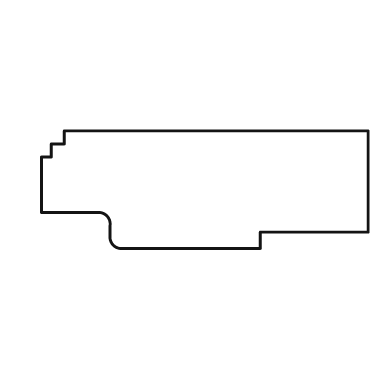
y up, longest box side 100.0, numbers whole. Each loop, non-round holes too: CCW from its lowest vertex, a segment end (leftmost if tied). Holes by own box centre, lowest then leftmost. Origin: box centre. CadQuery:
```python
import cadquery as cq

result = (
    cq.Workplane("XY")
    .moveTo(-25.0, -18.0)
    .lineTo(17.0, -18.0)
    .lineTo(17.0, -13.0)
    .lineTo(50.0, -13.0)
    .lineTo(50.0, 18.0)
    .lineTo(-43.0, 18.0)
    .lineTo(-43.0, 14.0)
    .lineTo(-47.0, 14.0)
    .lineTo(-47.0, 10.0)
    .lineTo(-50.0, 10.0)
    .lineTo(-50.0, -7.0)
    .lineTo(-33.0, -7.0)
    .threePointArc((-30.0, -8.0), (-29.0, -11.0))
    .lineTo(-29.0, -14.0)
    .threePointArc((-28.0, -17.0), (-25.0, -18.0))
    .close()
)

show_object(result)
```